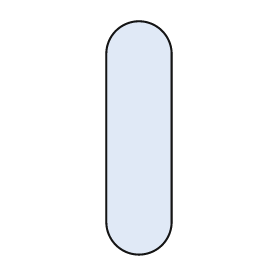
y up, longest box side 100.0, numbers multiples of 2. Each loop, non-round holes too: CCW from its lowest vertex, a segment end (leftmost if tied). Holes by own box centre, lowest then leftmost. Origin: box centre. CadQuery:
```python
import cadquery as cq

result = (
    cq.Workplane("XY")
    .moveTo(-14.0, -36.0)
    .threePointArc((0.0, -50.0), (14.0, -36.0))
    .lineTo(14.0, 36.0)
    .threePointArc((0.0, 50.0), (-14.0, 36.0))
    .close()
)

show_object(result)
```